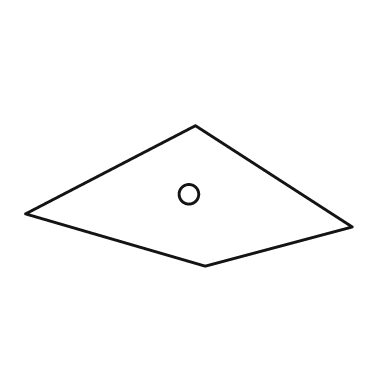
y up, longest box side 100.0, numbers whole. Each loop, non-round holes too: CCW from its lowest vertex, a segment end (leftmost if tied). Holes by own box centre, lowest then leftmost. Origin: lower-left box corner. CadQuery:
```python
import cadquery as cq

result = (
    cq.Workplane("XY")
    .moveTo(55.0, 0.0)
    .lineTo(100.0, 12.0)
    .lineTo(52.0, 43.0)
    .lineTo(0.0, 16.0)
    .close()
    .moveTo(50.0, 22.0)
    .circle(3.0)
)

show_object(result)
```